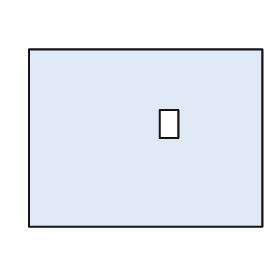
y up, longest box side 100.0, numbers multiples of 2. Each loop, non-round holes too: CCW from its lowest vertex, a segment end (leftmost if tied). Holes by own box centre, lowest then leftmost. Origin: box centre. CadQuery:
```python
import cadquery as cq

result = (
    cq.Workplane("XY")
    .moveTo(-50.0, -38.0)
    .lineTo(50.0, -38.0)
    .lineTo(50.0, 38.0)
    .lineTo(-50.0, 38.0)
    .close()
    .moveTo(6.0, 0.0)
    .lineTo(14.0, 0.0)
    .lineTo(14.0, 12.0)
    .lineTo(6.0, 12.0)
    .close()
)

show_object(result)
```